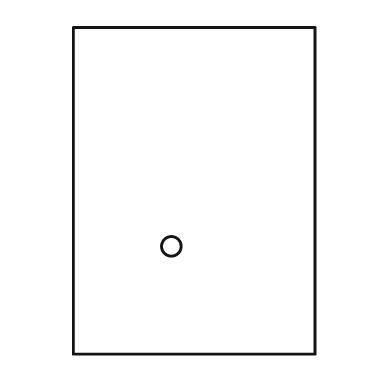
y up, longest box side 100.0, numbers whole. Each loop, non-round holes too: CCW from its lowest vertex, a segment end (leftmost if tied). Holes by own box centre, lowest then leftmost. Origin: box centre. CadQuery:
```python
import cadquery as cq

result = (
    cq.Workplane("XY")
    .moveTo(-37.0, -50.0)
    .lineTo(37.0, -50.0)
    .lineTo(37.0, 50.0)
    .lineTo(-37.0, 50.0)
    .close()
    .moveTo(-7.0, -17.0)
    .circle(3.0)
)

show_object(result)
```